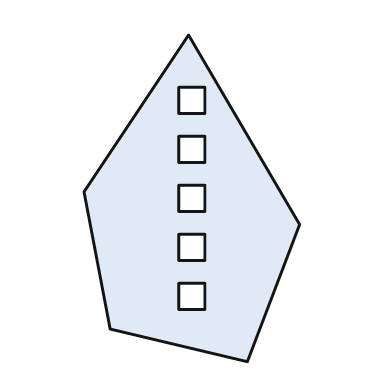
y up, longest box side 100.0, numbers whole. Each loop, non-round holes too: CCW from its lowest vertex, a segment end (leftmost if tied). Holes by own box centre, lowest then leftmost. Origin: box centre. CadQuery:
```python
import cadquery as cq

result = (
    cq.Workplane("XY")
    .moveTo(17.0, -50.0)
    .lineTo(33.0, -8.0)
    .lineTo(-1.0, 50.0)
    .lineTo(-33.0, 2.0)
    .lineTo(-25.0, -40.0)
    .close()
    .moveTo(-4.0, -34.0)
    .lineTo(4.0, -34.0)
    .lineTo(4.0, -26.0)
    .lineTo(-4.0, -26.0)
    .close()
    .moveTo(-4.0, -19.0)
    .lineTo(4.0, -19.0)
    .lineTo(4.0, -11.0)
    .lineTo(-4.0, -11.0)
    .close()
    .moveTo(-4.0, -4.0)
    .lineTo(4.0, -4.0)
    .lineTo(4.0, 4.0)
    .lineTo(-4.0, 4.0)
    .close()
    .moveTo(-4.0, 11.0)
    .lineTo(4.0, 11.0)
    .lineTo(4.0, 19.0)
    .lineTo(-4.0, 19.0)
    .close()
    .moveTo(-4.0, 26.0)
    .lineTo(4.0, 26.0)
    .lineTo(4.0, 34.0)
    .lineTo(-4.0, 34.0)
    .close()
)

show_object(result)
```